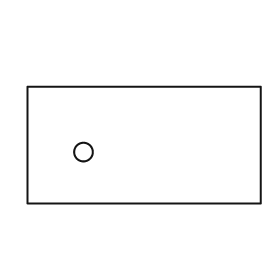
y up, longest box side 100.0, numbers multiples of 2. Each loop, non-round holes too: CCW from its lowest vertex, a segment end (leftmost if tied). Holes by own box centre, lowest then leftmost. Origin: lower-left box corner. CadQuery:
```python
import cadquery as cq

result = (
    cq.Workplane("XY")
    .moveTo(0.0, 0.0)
    .lineTo(100.0, 0.0)
    .lineTo(100.0, 50.0)
    .lineTo(0.0, 50.0)
    .close()
    .moveTo(24.0, 22.0)
    .circle(4.0)
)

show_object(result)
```